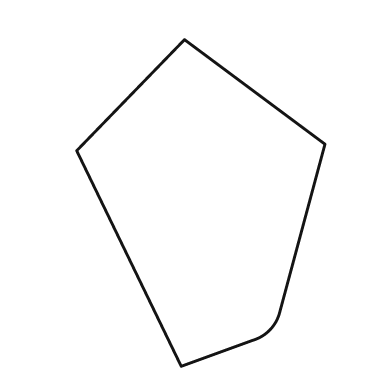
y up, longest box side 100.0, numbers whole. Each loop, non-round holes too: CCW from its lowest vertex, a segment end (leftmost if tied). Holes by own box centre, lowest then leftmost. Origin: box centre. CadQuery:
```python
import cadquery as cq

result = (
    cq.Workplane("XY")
    .moveTo(-6.0, -50.0)
    .lineTo(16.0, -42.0)
    .threePointArc((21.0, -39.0), (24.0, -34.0))
    .lineTo(38.0, 18.0)
    .lineTo(-5.0, 50.0)
    .lineTo(-38.0, 16.0)
    .close()
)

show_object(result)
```